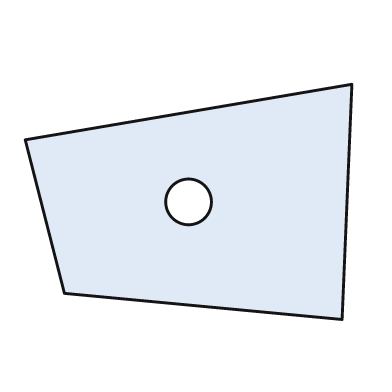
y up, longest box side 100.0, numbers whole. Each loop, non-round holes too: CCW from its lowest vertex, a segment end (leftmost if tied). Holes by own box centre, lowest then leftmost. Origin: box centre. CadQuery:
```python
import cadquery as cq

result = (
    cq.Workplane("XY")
    .moveTo(47.0, -36.0)
    .lineTo(50.0, 36.0)
    .lineTo(-50.0, 19.0)
    .lineTo(-38.0, -28.0)
    .close()
    .moveTo(0.0, 0.0)
    .circle(7.0)
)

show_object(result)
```